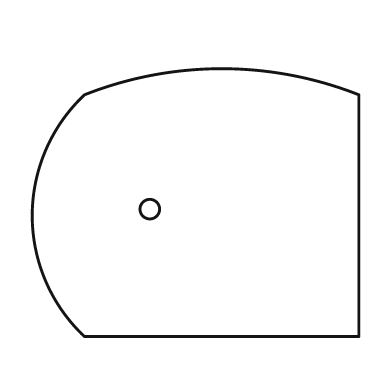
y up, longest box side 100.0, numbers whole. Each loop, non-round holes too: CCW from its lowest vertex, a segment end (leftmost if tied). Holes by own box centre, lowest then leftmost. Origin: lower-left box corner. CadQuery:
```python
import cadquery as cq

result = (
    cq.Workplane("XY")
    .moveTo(16.0, 0.0)
    .lineTo(100.0, 0.0)
    .lineTo(100.0, 74.0)
    .threePointArc((58.0, 82.0), (16.0, 74.0))
    .threePointArc((0.0, 37.0), (16.0, 0.0))
    .close()
    .moveTo(36.0, 39.0)
    .circle(3.0)
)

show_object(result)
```